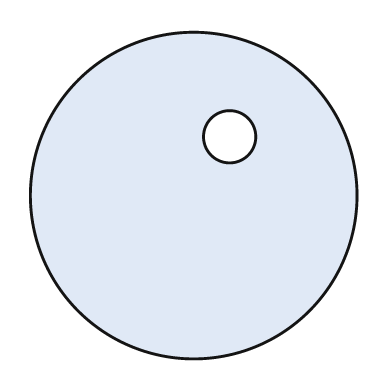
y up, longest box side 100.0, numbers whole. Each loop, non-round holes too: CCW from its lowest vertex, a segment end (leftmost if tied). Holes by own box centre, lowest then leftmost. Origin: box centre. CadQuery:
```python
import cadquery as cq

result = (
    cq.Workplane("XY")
    .moveTo(0.0, 0.0)
    .circle(50.0)
    .moveTo(11.0, 18.0)
    .circle(8.0)
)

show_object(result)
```